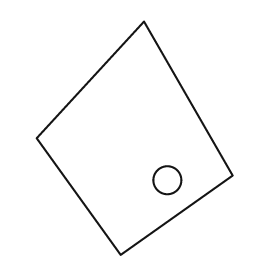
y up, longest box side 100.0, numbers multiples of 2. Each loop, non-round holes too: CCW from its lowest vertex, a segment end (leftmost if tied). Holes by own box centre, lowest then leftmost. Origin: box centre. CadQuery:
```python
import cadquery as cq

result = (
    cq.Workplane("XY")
    .moveTo(-6.0, -50.0)
    .lineTo(42.0, -16.0)
    .lineTo(4.0, 50.0)
    .lineTo(-42.0, 0.0)
    .close()
    .moveTo(14.0, -18.0)
    .circle(6.0)
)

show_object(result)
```